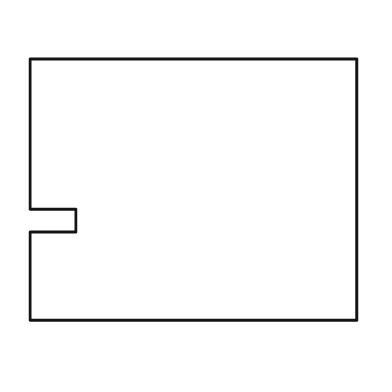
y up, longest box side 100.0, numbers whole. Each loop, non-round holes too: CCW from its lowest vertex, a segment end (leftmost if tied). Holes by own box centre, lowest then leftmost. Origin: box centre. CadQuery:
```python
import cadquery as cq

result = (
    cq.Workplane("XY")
    .moveTo(-50.0, -40.0)
    .lineTo(50.0, -40.0)
    .lineTo(50.0, 40.0)
    .lineTo(-50.0, 40.0)
    .lineTo(-50.0, -6.0)
    .lineTo(-36.0, -6.0)
    .lineTo(-36.0, -13.0)
    .lineTo(-50.0, -13.0)
    .close()
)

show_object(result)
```